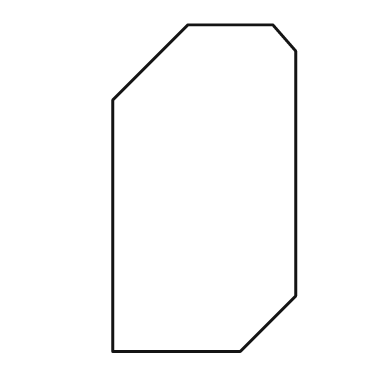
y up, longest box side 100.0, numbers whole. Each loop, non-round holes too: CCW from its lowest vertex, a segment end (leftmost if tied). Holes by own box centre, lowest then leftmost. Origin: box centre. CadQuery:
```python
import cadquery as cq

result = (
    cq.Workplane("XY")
    .moveTo(-28.0, -50.0)
    .lineTo(11.0, -50.0)
    .lineTo(28.0, -33.0)
    .lineTo(28.0, 42.0)
    .lineTo(21.0, 50.0)
    .lineTo(-5.0, 50.0)
    .lineTo(-28.0, 27.0)
    .close()
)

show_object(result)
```